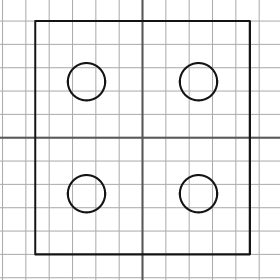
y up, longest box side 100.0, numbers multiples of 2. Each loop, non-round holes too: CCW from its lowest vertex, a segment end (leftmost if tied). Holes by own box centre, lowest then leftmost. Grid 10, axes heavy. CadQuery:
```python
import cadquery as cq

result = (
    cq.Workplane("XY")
    .moveTo(-46.0, -50.0)
    .lineTo(46.0, -50.0)
    .lineTo(46.0, 50.0)
    .lineTo(-46.0, 50.0)
    .close()
    .moveTo(-24.0, -24.0)
    .circle(8.0)
    .moveTo(24.0, -24.0)
    .circle(8.0)
    .moveTo(-24.0, 24.0)
    .circle(8.0)
    .moveTo(24.0, 24.0)
    .circle(8.0)
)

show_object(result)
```